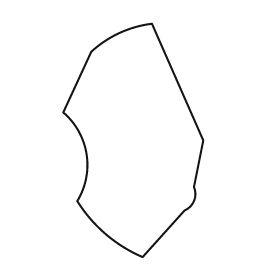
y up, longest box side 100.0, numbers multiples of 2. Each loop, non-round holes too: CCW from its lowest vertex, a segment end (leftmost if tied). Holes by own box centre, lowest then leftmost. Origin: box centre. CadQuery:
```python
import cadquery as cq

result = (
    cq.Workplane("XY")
    .moveTo(4.0, -50.0)
    .lineTo(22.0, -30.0)
    .threePointArc((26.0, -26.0), (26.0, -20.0))
    .lineTo(30.0, 0.0)
    .lineTo(8.0, 50.0)
    .threePointArc((-6.0, 46.0), (-18.0, 38.0))
    .lineTo(-30.0, 12.0)
    .threePointArc((-20.0, -6.0), (-24.0, -26.0))
    .threePointArc((-12.0, -40.0), (4.0, -50.0))
    .close()
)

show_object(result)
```